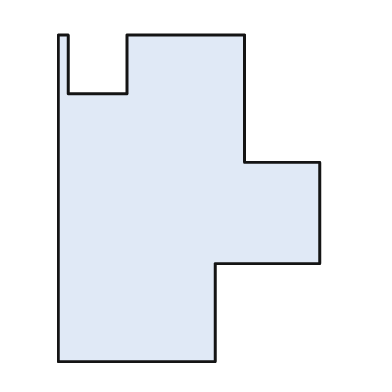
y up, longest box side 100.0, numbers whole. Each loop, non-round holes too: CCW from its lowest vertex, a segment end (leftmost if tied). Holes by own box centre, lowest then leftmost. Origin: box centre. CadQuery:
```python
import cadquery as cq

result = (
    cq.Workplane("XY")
    .moveTo(-40.0, -50.0)
    .lineTo(8.0, -50.0)
    .lineTo(8.0, -20.0)
    .lineTo(40.0, -20.0)
    .lineTo(40.0, 11.0)
    .lineTo(17.0, 11.0)
    .lineTo(17.0, 50.0)
    .lineTo(-19.0, 50.0)
    .lineTo(-19.0, 32.0)
    .lineTo(-37.0, 32.0)
    .lineTo(-37.0, 50.0)
    .lineTo(-40.0, 50.0)
    .close()
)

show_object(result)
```